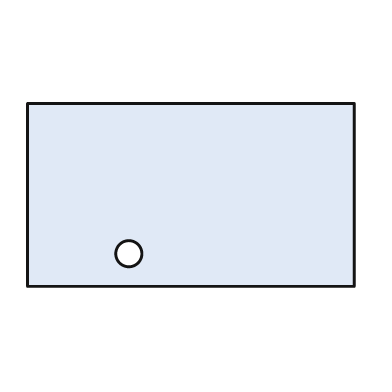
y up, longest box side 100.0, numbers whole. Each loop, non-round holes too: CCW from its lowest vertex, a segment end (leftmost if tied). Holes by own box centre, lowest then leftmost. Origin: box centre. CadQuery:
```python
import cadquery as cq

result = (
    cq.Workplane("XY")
    .moveTo(-50.0, -28.0)
    .lineTo(50.0, -28.0)
    .lineTo(50.0, 28.0)
    .lineTo(-50.0, 28.0)
    .close()
    .moveTo(-19.0, -18.0)
    .circle(4.0)
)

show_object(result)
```